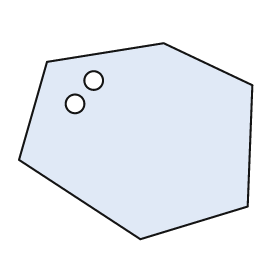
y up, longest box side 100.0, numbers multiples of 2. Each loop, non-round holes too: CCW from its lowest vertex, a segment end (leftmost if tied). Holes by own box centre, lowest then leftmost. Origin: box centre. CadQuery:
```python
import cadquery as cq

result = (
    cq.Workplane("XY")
    .moveTo(2.0, -42.0)
    .lineTo(48.0, -28.0)
    .lineTo(50.0, 24.0)
    .lineTo(12.0, 42.0)
    .lineTo(-38.0, 34.0)
    .lineTo(-50.0, -8.0)
    .close()
    .moveTo(-26.0, 16.0)
    .circle(4.0)
    .moveTo(-18.0, 26.0)
    .circle(4.0)
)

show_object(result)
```